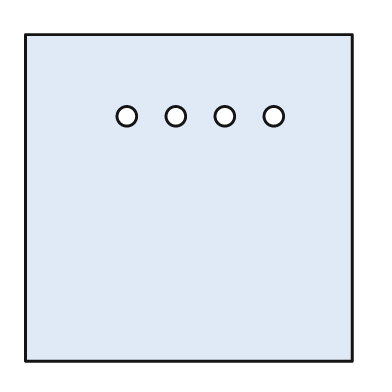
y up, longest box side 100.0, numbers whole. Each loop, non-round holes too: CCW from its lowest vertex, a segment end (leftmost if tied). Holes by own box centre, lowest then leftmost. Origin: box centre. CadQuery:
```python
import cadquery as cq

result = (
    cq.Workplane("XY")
    .moveTo(-50.0, -50.0)
    .lineTo(50.0, -50.0)
    .lineTo(50.0, 50.0)
    .lineTo(-50.0, 50.0)
    .close()
    .moveTo(-19.0, 25.0)
    .circle(3.0)
    .moveTo(-4.0, 25.0)
    .circle(3.0)
    .moveTo(11.0, 25.0)
    .circle(3.0)
    .moveTo(26.0, 25.0)
    .circle(3.0)
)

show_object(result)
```